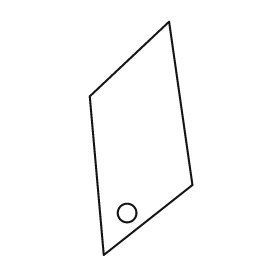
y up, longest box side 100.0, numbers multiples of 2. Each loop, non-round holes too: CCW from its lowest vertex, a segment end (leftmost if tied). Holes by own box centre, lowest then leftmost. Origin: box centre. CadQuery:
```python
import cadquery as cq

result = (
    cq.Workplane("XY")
    .moveTo(-16.0, -50.0)
    .lineTo(22.0, -20.0)
    .lineTo(12.0, 50.0)
    .lineTo(-22.0, 18.0)
    .close()
    .moveTo(-6.0, -32.0)
    .circle(4.0)
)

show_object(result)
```